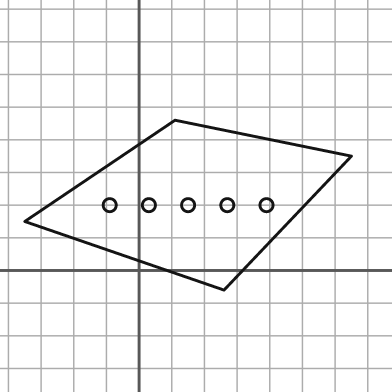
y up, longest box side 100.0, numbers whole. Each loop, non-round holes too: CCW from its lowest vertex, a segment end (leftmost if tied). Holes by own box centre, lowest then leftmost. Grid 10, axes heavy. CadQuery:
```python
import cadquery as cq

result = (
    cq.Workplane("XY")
    .moveTo(26.0, -6.0)
    .lineTo(65.0, 35.0)
    .lineTo(11.0, 46.0)
    .lineTo(-35.0, 15.0)
    .close()
    .moveTo(-9.0, 20.0)
    .circle(2.0)
    .moveTo(3.0, 20.0)
    .circle(2.0)
    .moveTo(15.0, 20.0)
    .circle(2.0)
    .moveTo(27.0, 20.0)
    .circle(2.0)
    .moveTo(39.0, 20.0)
    .circle(2.0)
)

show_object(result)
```